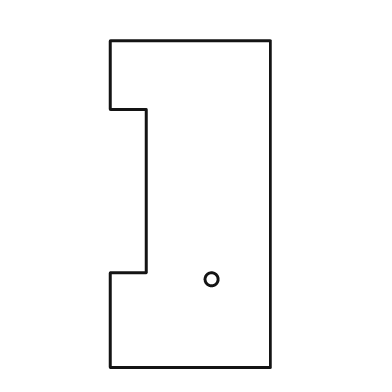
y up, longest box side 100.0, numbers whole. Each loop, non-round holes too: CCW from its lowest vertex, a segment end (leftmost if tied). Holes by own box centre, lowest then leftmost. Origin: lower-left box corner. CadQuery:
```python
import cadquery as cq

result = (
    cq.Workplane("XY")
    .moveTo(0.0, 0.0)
    .lineTo(49.0, 0.0)
    .lineTo(49.0, 100.0)
    .lineTo(0.0, 100.0)
    .lineTo(0.0, 79.0)
    .lineTo(11.0, 79.0)
    .lineTo(11.0, 29.0)
    .lineTo(0.0, 29.0)
    .close()
    .moveTo(31.0, 27.0)
    .circle(2.0)
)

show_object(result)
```